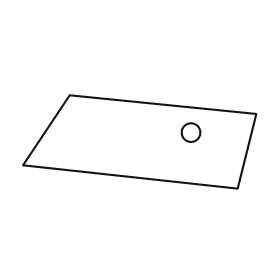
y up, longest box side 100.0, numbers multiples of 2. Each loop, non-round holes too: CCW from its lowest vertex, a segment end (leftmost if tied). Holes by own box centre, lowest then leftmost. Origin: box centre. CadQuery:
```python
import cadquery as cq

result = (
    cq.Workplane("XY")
    .moveTo(42.0, -20.0)
    .lineTo(50.0, 12.0)
    .lineTo(-30.0, 20.0)
    .lineTo(-50.0, -10.0)
    .close()
    .moveTo(22.0, 4.0)
    .circle(4.0)
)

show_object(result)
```